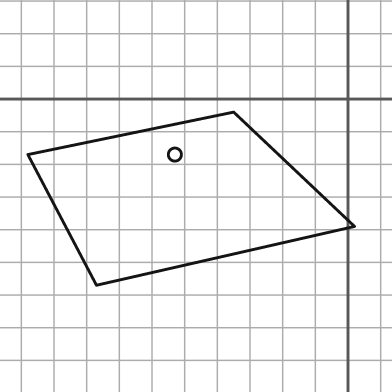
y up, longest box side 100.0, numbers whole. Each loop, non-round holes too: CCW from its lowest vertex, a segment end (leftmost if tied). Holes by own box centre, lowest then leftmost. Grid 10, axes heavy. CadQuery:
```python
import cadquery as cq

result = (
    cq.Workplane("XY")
    .moveTo(-77.0, -57.0)
    .lineTo(2.0, -39.0)
    .lineTo(-35.0, -4.0)
    .lineTo(-98.0, -17.0)
    .close()
    .moveTo(-53.0, -17.0)
    .circle(2.0)
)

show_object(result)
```